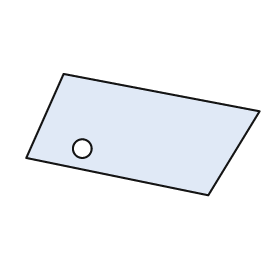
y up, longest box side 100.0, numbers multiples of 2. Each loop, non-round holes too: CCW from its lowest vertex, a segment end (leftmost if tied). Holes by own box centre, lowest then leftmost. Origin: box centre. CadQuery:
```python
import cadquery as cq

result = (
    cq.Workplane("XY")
    .moveTo(28.0, -26.0)
    .lineTo(50.0, 10.0)
    .lineTo(-34.0, 26.0)
    .lineTo(-50.0, -10.0)
    .close()
    .moveTo(-26.0, -6.0)
    .circle(4.0)
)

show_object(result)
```